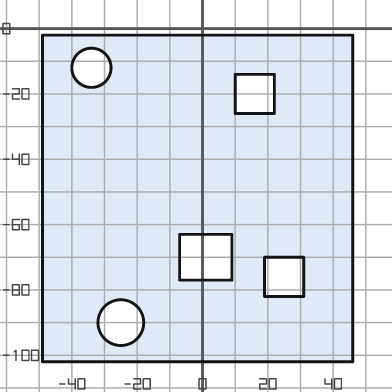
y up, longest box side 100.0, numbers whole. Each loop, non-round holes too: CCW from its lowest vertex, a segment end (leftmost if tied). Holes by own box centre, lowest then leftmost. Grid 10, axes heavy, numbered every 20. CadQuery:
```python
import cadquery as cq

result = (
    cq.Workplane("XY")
    .moveTo(-49.0, -102.0)
    .lineTo(46.0, -102.0)
    .lineTo(46.0, -2.0)
    .lineTo(-49.0, -2.0)
    .close()
    .moveTo(-25.0, -90.0)
    .circle(7.0)
    .moveTo(19.0, -82.0)
    .lineTo(31.0, -82.0)
    .lineTo(31.0, -70.0)
    .lineTo(19.0, -70.0)
    .close()
    .moveTo(-7.0, -77.0)
    .lineTo(9.0, -77.0)
    .lineTo(9.0, -63.0)
    .lineTo(-7.0, -63.0)
    .close()
    .moveTo(10.0, -26.0)
    .lineTo(22.0, -26.0)
    .lineTo(22.0, -14.0)
    .lineTo(10.0, -14.0)
    .close()
    .moveTo(-34.0, -12.0)
    .circle(6.0)
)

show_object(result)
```